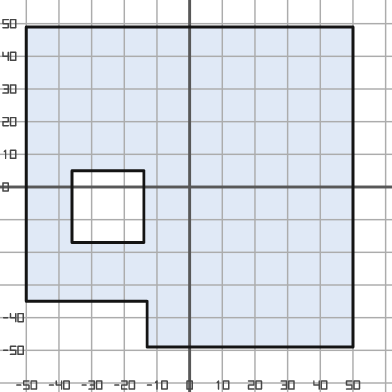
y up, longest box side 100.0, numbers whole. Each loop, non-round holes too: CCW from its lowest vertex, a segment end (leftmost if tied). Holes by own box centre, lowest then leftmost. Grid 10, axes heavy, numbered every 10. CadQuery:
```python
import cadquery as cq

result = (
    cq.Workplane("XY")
    .moveTo(-13.0, -49.0)
    .lineTo(50.0, -49.0)
    .lineTo(50.0, 49.0)
    .lineTo(-50.0, 49.0)
    .lineTo(-50.0, -35.0)
    .lineTo(-13.0, -35.0)
    .close()
    .moveTo(-36.0, -17.0)
    .lineTo(-14.0, -17.0)
    .lineTo(-14.0, 5.0)
    .lineTo(-36.0, 5.0)
    .close()
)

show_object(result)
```